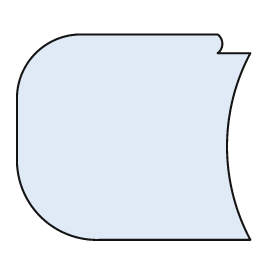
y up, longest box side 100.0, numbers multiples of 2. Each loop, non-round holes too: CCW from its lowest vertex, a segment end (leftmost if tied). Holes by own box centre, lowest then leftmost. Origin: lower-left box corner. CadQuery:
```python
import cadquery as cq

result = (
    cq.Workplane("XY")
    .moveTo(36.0, 0.0)
    .lineTo(100.0, 0.0)
    .threePointArc((90.0, 40.0), (100.0, 80.0))
    .lineTo(86.0, 80.0)
    .threePointArc((88.0, 84.0), (86.0, 88.0))
    .lineTo(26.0, 88.0)
    .threePointArc((8.0, 80.0), (0.0, 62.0))
    .lineTo(0.0, 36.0)
    .threePointArc((10.0, 10.0), (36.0, 0.0))
    .close()
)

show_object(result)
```